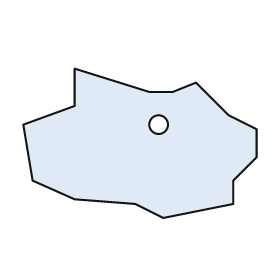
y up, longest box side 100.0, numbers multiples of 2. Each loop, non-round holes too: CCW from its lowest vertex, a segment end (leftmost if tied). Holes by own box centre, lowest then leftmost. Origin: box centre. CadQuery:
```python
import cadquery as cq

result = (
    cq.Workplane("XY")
    .moveTo(10.0, -32.0)
    .lineTo(40.0, -26.0)
    .lineTo(40.0, -16.0)
    .lineTo(50.0, -6.0)
    .lineTo(50.0, 6.0)
    .lineTo(38.0, 12.0)
    .lineTo(24.0, 26.0)
    .lineTo(14.0, 22.0)
    .lineTo(4.0, 22.0)
    .lineTo(-28.0, 32.0)
    .lineTo(-28.0, 16.0)
    .lineTo(-50.0, 8.0)
    .lineTo(-46.0, -16.0)
    .lineTo(-28.0, -24.0)
    .lineTo(-2.0, -26.0)
    .close()
    .moveTo(8.0, 8.0)
    .circle(4.0)
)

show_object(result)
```